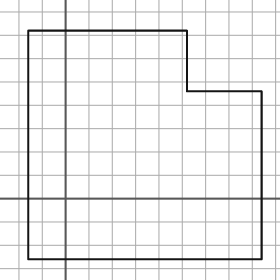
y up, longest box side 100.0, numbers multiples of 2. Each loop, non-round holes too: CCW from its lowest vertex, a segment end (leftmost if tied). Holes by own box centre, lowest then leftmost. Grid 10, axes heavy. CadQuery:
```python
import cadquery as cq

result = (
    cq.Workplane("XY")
    .moveTo(-16.0, -26.0)
    .lineTo(84.0, -26.0)
    .lineTo(84.0, 46.0)
    .lineTo(52.0, 46.0)
    .lineTo(52.0, 72.0)
    .lineTo(-16.0, 72.0)
    .close()
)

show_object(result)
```